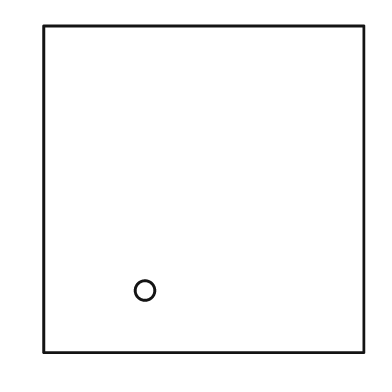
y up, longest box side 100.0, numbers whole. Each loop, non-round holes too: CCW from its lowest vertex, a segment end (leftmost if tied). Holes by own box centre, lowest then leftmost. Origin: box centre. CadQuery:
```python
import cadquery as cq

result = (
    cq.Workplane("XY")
    .moveTo(-49.0, -50.0)
    .lineTo(49.0, -50.0)
    .lineTo(49.0, 50.0)
    .lineTo(-49.0, 50.0)
    .close()
    .moveTo(-18.0, -31.0)
    .circle(3.0)
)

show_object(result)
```